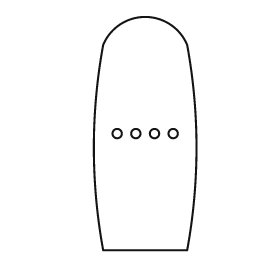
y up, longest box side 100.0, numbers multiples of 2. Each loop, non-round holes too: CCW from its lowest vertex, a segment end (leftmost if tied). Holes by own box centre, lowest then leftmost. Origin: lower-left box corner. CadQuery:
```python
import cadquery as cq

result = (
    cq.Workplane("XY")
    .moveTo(4.0, 0.0)
    .lineTo(40.0, 0.0)
    .threePointArc((44.0, 44.0), (40.0, 88.0))
    .threePointArc((22.0, 100.0), (4.0, 88.0))
    .threePointArc((0.0, 44.0), (4.0, 0.0))
    .close()
    .moveTo(10.0, 50.0)
    .circle(2.0)
    .moveTo(18.0, 50.0)
    .circle(2.0)
    .moveTo(26.0, 50.0)
    .circle(2.0)
    .moveTo(34.0, 50.0)
    .circle(2.0)
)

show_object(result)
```